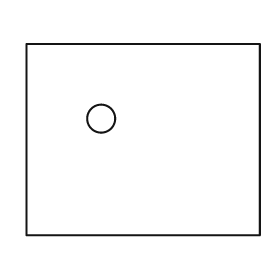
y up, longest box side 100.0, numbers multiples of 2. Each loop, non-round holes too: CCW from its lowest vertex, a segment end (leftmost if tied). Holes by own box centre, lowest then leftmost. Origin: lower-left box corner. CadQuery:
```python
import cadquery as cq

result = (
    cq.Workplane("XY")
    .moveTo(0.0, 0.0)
    .lineTo(100.0, 0.0)
    .lineTo(100.0, 82.0)
    .lineTo(0.0, 82.0)
    .close()
    .moveTo(32.0, 50.0)
    .circle(6.0)
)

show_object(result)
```